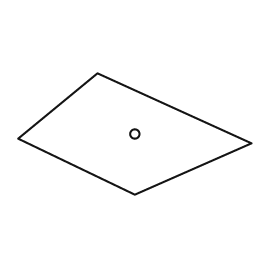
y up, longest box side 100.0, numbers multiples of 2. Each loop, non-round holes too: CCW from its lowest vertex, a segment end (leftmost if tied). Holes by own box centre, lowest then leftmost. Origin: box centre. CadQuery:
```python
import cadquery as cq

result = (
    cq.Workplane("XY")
    .moveTo(0.0, -26.0)
    .lineTo(50.0, -4.0)
    .lineTo(-16.0, 26.0)
    .lineTo(-50.0, -2.0)
    .close()
    .moveTo(0.0, 0.0)
    .circle(2.0)
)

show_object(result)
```